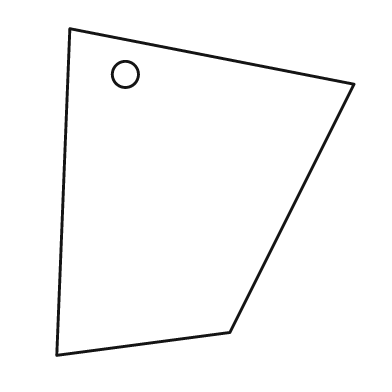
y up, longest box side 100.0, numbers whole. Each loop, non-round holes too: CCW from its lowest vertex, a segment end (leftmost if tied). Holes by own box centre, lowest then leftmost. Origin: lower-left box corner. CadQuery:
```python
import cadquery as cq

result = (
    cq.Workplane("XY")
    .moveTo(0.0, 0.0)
    .lineTo(53.0, 7.0)
    .lineTo(91.0, 83.0)
    .lineTo(4.0, 100.0)
    .close()
    .moveTo(21.0, 86.0)
    .circle(4.0)
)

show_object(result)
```